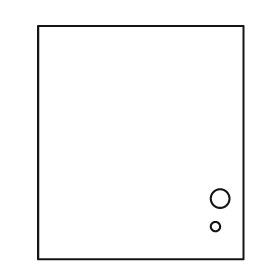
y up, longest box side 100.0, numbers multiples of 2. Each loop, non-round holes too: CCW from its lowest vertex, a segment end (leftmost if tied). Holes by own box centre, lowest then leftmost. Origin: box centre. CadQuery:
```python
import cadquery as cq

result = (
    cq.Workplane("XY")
    .moveTo(-44.0, -50.0)
    .lineTo(44.0, -50.0)
    .lineTo(44.0, 50.0)
    .lineTo(-44.0, 50.0)
    .close()
    .moveTo(32.0, -36.0)
    .circle(2.0)
    .moveTo(34.0, -24.0)
    .circle(4.0)
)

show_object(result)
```